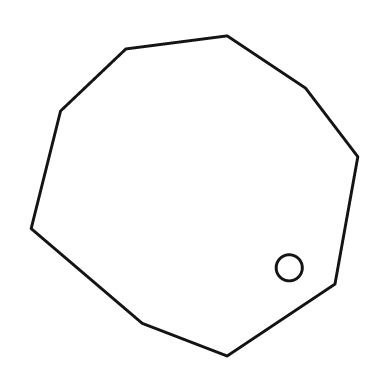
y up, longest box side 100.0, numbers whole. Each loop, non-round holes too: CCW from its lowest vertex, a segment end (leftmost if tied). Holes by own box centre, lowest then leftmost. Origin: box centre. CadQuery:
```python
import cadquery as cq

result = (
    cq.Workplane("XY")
    .moveTo(10.0, -49.0)
    .lineTo(43.0, -27.0)
    .lineTo(50.0, 12.0)
    .lineTo(34.0, 33.0)
    .lineTo(10.0, 49.0)
    .lineTo(-21.0, 45.0)
    .lineTo(-41.0, 26.0)
    .lineTo(-50.0, -10.0)
    .lineTo(-16.0, -39.0)
    .close()
    .moveTo(29.0, -22.0)
    .circle(4.0)
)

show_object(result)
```